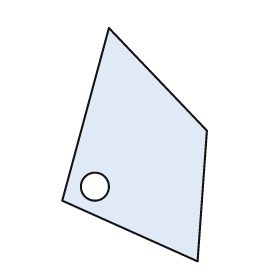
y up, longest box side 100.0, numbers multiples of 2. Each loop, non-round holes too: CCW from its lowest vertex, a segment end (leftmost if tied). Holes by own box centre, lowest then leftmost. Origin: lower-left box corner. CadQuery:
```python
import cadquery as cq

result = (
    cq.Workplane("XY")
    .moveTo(58.0, 0.0)
    .lineTo(62.0, 56.0)
    .lineTo(20.0, 100.0)
    .lineTo(0.0, 26.0)
    .close()
    .moveTo(14.0, 32.0)
    .circle(6.0)
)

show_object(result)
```